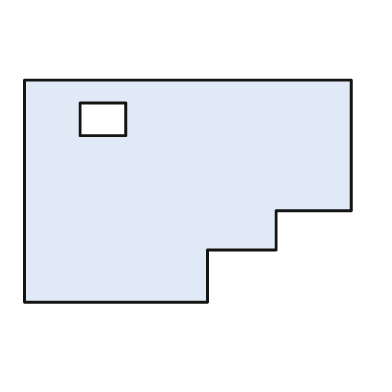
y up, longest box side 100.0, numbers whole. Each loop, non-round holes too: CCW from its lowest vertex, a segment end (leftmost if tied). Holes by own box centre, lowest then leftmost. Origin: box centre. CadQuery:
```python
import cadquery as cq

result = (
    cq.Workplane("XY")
    .moveTo(-50.0, -34.0)
    .lineTo(6.0, -34.0)
    .lineTo(6.0, -18.0)
    .lineTo(27.0, -18.0)
    .lineTo(27.0, -6.0)
    .lineTo(50.0, -6.0)
    .lineTo(50.0, 34.0)
    .lineTo(-50.0, 34.0)
    .close()
    .moveTo(-33.0, 17.0)
    .lineTo(-19.0, 17.0)
    .lineTo(-19.0, 27.0)
    .lineTo(-33.0, 27.0)
    .close()
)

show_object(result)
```